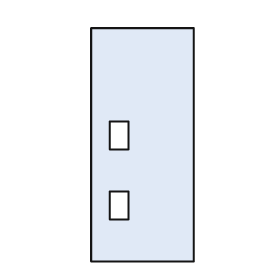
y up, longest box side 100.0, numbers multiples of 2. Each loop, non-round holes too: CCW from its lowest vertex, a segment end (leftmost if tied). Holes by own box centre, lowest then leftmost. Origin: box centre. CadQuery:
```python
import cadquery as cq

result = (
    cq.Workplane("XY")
    .moveTo(-22.0, -50.0)
    .lineTo(22.0, -50.0)
    .lineTo(22.0, 50.0)
    .lineTo(-22.0, 50.0)
    .close()
    .moveTo(-14.0, -32.0)
    .lineTo(-6.0, -32.0)
    .lineTo(-6.0, -20.0)
    .lineTo(-14.0, -20.0)
    .close()
    .moveTo(-14.0, -2.0)
    .lineTo(-6.0, -2.0)
    .lineTo(-6.0, 10.0)
    .lineTo(-14.0, 10.0)
    .close()
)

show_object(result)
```